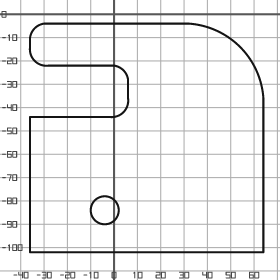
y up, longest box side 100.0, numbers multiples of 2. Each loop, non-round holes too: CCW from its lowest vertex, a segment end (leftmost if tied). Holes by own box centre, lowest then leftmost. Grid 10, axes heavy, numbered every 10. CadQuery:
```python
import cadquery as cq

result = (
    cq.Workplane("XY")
    .moveTo(-36.0, -102.0)
    .lineTo(64.0, -102.0)
    .lineTo(64.0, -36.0)
    .threePointArc((54.0, -14.0), (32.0, -4.0))
    .lineTo(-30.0, -4.0)
    .threePointArc((-34.0, -6.0), (-36.0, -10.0))
    .lineTo(-36.0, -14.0)
    .threePointArc((-34.0, -20.0), (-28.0, -22.0))
    .lineTo(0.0, -22.0)
    .threePointArc((4.0, -24.0), (6.0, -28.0))
    .lineTo(6.0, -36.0)
    .threePointArc((4.0, -42.0), (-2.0, -44.0))
    .lineTo(-36.0, -44.0)
    .close()
    .moveTo(-4.0, -84.0)
    .circle(6.0)
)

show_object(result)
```